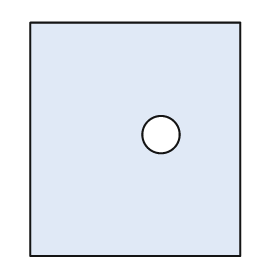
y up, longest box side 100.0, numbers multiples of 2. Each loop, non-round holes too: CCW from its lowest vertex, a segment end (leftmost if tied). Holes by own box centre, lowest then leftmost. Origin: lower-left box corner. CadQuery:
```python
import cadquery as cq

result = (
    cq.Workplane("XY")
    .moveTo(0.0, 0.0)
    .lineTo(90.0, 0.0)
    .lineTo(90.0, 100.0)
    .lineTo(0.0, 100.0)
    .close()
    .moveTo(56.0, 52.0)
    .circle(8.0)
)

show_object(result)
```